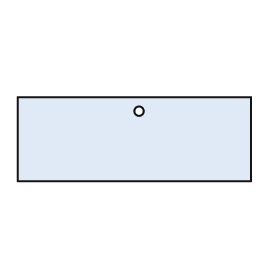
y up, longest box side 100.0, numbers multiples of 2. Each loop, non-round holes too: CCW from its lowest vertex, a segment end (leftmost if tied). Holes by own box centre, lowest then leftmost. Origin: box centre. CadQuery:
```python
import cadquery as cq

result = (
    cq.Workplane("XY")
    .moveTo(-50.0, -18.0)
    .lineTo(50.0, -18.0)
    .lineTo(50.0, 18.0)
    .lineTo(-50.0, 18.0)
    .close()
    .moveTo(2.0, 12.0)
    .circle(2.0)
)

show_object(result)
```